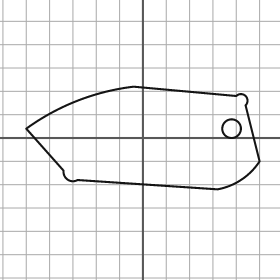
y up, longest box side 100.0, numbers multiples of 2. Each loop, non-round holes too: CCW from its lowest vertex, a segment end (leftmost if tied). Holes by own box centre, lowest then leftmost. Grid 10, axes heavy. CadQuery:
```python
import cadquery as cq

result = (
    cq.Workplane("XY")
    .moveTo(32.0, -22.0)
    .threePointArc((42.0, -18.0), (50.0, -10.0))
    .lineTo(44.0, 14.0)
    .threePointArc((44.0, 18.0), (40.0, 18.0))
    .lineTo(-4.0, 22.0)
    .threePointArc((-28.0, 16.0), (-50.0, 4.0))
    .lineTo(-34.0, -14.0)
    .threePointArc((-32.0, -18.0), (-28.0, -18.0))
    .close()
    .moveTo(38.0, 4.0)
    .circle(4.0)
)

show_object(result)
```